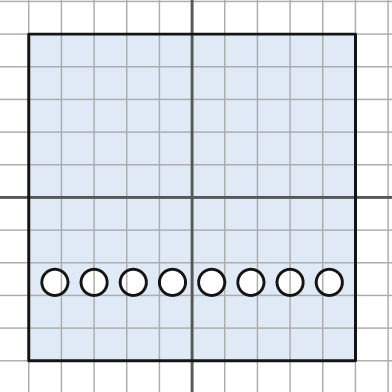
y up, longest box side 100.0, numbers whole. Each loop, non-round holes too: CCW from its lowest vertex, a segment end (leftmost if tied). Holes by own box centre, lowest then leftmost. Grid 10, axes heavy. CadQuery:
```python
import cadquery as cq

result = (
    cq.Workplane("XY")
    .moveTo(-50.0, -50.0)
    .lineTo(50.0, -50.0)
    .lineTo(50.0, 50.0)
    .lineTo(-50.0, 50.0)
    .close()
    .moveTo(-42.0, -26.0)
    .circle(4.0)
    .moveTo(-30.0, -26.0)
    .circle(4.0)
    .moveTo(-18.0, -26.0)
    .circle(4.0)
    .moveTo(-6.0, -26.0)
    .circle(4.0)
    .moveTo(6.0, -26.0)
    .circle(4.0)
    .moveTo(18.0, -26.0)
    .circle(4.0)
    .moveTo(30.0, -26.0)
    .circle(4.0)
    .moveTo(42.0, -26.0)
    .circle(4.0)
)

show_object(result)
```